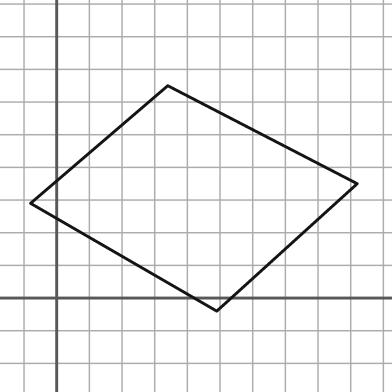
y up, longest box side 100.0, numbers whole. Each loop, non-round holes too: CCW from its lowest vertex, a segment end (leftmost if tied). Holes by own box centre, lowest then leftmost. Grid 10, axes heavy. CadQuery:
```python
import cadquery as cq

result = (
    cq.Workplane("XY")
    .moveTo(49.0, -4.0)
    .lineTo(92.0, 35.0)
    .lineTo(34.0, 65.0)
    .lineTo(-8.0, 29.0)
    .close()
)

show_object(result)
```